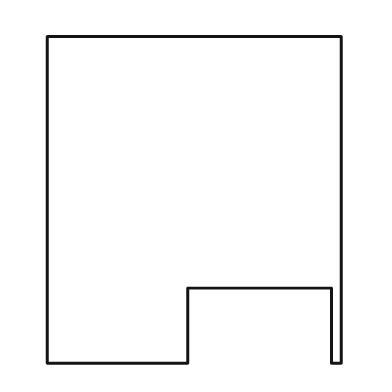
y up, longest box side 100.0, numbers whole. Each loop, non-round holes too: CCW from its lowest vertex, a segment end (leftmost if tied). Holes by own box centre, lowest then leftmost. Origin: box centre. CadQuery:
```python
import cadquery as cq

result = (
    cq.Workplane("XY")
    .moveTo(-45.0, -50.0)
    .lineTo(-2.0, -50.0)
    .lineTo(-2.0, -27.0)
    .lineTo(42.0, -27.0)
    .lineTo(42.0, -50.0)
    .lineTo(45.0, -50.0)
    .lineTo(45.0, 50.0)
    .lineTo(-45.0, 50.0)
    .close()
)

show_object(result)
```